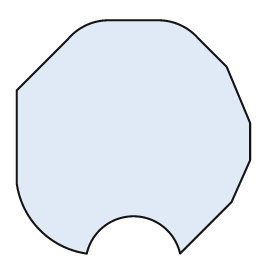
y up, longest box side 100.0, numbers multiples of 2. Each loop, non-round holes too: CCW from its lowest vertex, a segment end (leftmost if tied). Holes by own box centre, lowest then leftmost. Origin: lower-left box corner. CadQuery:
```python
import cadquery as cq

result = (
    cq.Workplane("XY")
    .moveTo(30.0, 0.0)
    .threePointArc((50.0, 16.0), (70.0, 0.0))
    .lineTo(92.0, 22.0)
    .lineTo(100.0, 40.0)
    .lineTo(100.0, 56.0)
    .lineTo(90.0, 80.0)
    .lineTo(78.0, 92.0)
    .threePointArc((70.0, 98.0), (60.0, 100.0))
    .lineTo(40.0, 100.0)
    .threePointArc((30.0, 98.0), (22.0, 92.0))
    .lineTo(0.0, 70.0)
    .lineTo(0.0, 30.0)
    .threePointArc((10.0, 10.0), (30.0, 0.0))
    .close()
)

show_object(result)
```